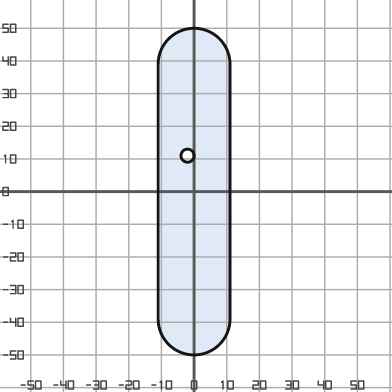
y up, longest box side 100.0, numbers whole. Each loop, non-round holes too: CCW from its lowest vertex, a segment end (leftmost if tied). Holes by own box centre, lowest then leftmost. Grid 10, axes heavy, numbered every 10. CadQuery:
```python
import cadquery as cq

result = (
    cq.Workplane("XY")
    .moveTo(-11.0, -39.0)
    .threePointArc((0.0, -50.0), (11.0, -39.0))
    .lineTo(11.0, 39.0)
    .threePointArc((0.0, 50.0), (-11.0, 39.0))
    .close()
    .moveTo(-2.0, 11.0)
    .circle(2.0)
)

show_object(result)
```